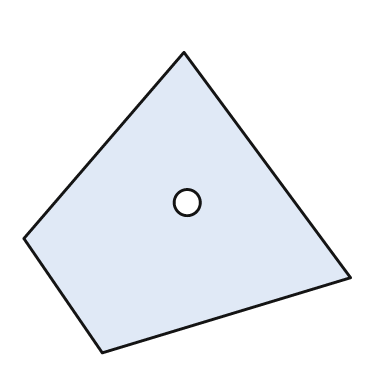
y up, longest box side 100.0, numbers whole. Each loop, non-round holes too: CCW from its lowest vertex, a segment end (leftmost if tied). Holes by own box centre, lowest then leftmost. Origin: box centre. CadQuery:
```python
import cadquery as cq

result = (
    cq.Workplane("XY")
    .moveTo(-26.0, -46.0)
    .lineTo(50.0, -23.0)
    .lineTo(-1.0, 46.0)
    .lineTo(-50.0, -11.0)
    .close()
    .moveTo(0.0, 0.0)
    .circle(4.0)
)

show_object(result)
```